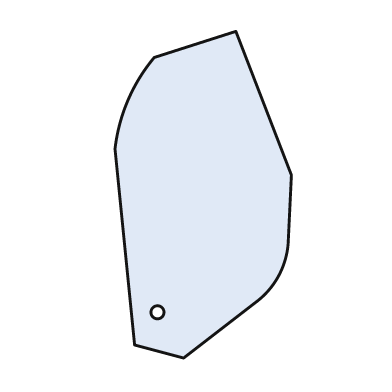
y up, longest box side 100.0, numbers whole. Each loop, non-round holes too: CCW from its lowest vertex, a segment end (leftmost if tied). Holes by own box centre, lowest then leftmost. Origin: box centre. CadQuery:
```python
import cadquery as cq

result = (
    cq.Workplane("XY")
    .moveTo(-6.0, -50.0)
    .lineTo(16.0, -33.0)
    .threePointArc((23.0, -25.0), (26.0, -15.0))
    .lineTo(27.0, 6.0)
    .lineTo(10.0, 50.0)
    .lineTo(-15.0, 42.0)
    .threePointArc((-23.0, 29.0), (-27.0, 14.0))
    .lineTo(-21.0, -46.0)
    .close()
    .moveTo(-14.0, -36.0)
    .circle(2.0)
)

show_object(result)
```